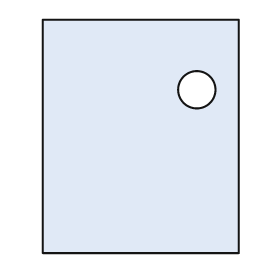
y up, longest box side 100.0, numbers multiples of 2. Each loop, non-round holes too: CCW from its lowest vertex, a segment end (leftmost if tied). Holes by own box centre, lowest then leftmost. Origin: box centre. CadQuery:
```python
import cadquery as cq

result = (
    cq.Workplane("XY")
    .moveTo(-42.0, -50.0)
    .lineTo(42.0, -50.0)
    .lineTo(42.0, 50.0)
    .lineTo(-42.0, 50.0)
    .close()
    .moveTo(24.0, 20.0)
    .circle(8.0)
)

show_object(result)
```